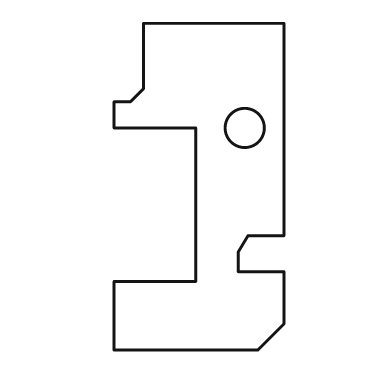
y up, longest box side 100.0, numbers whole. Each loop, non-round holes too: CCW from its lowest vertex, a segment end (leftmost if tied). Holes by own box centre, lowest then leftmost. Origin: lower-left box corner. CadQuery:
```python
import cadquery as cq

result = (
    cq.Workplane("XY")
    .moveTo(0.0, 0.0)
    .lineTo(44.0, 0.0)
    .lineTo(52.0, 8.0)
    .lineTo(52.0, 24.0)
    .lineTo(38.0, 24.0)
    .lineTo(38.0, 30.0)
    .lineTo(41.0, 35.0)
    .lineTo(52.0, 35.0)
    .lineTo(52.0, 100.0)
    .lineTo(9.0, 100.0)
    .lineTo(9.0, 80.0)
    .lineTo(5.0, 76.0)
    .lineTo(0.0, 76.0)
    .lineTo(0.0, 68.0)
    .lineTo(25.0, 68.0)
    .lineTo(25.0, 21.0)
    .lineTo(0.0, 21.0)
    .close()
    .moveTo(40.0, 68.0)
    .circle(6.0)
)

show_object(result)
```